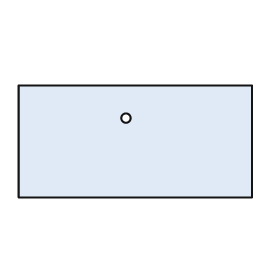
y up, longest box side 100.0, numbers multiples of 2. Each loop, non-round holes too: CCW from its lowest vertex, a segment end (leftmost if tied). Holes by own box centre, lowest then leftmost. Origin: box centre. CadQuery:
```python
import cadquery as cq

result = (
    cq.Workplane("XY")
    .moveTo(-50.0, -24.0)
    .lineTo(50.0, -24.0)
    .lineTo(50.0, 24.0)
    .lineTo(-50.0, 24.0)
    .close()
    .moveTo(-4.0, 10.0)
    .circle(2.0)
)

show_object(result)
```